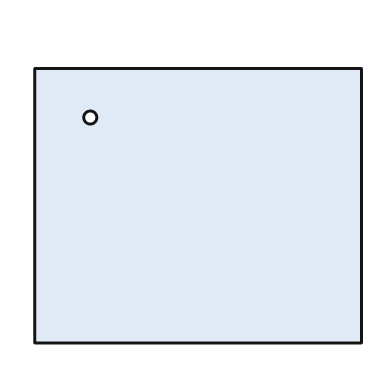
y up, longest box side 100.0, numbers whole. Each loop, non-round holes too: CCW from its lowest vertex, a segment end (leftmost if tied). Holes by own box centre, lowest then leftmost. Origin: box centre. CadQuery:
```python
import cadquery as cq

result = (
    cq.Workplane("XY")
    .moveTo(-50.0, -42.0)
    .lineTo(50.0, -42.0)
    .lineTo(50.0, 42.0)
    .lineTo(-50.0, 42.0)
    .close()
    .moveTo(-33.0, 27.0)
    .circle(2.0)
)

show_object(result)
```